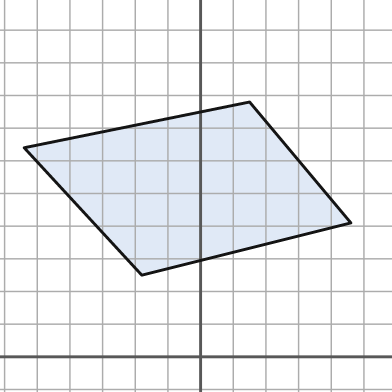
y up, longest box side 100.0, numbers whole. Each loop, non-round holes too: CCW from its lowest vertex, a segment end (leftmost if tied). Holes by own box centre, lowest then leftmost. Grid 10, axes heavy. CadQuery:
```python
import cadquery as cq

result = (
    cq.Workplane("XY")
    .moveTo(-18.0, 25.0)
    .lineTo(46.0, 41.0)
    .lineTo(15.0, 78.0)
    .lineTo(-54.0, 64.0)
    .close()
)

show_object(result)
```